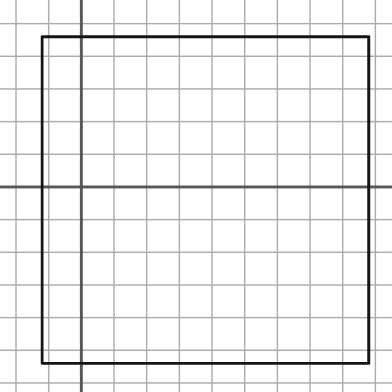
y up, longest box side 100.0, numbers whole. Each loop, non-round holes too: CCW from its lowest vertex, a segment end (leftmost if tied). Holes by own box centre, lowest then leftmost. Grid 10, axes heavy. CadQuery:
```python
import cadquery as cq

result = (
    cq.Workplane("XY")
    .moveTo(-12.0, -54.0)
    .lineTo(88.0, -54.0)
    .lineTo(88.0, 46.0)
    .lineTo(-12.0, 46.0)
    .close()
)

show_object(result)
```